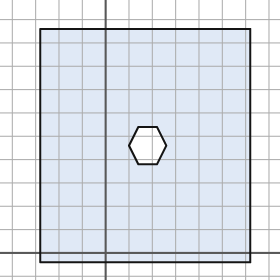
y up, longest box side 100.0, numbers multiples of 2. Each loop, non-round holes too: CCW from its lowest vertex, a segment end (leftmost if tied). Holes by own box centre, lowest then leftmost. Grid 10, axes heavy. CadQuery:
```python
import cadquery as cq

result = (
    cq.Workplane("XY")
    .moveTo(-28.0, -4.0)
    .lineTo(62.0, -4.0)
    .lineTo(62.0, 96.0)
    .lineTo(-28.0, 96.0)
    .close()
    .moveTo(14.0, 38.0)
    .lineTo(22.0, 38.0)
    .lineTo(26.0, 46.0)
    .lineTo(22.0, 54.0)
    .lineTo(14.0, 54.0)
    .lineTo(10.0, 46.0)
    .close()
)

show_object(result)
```